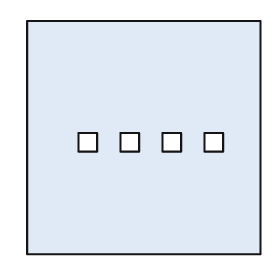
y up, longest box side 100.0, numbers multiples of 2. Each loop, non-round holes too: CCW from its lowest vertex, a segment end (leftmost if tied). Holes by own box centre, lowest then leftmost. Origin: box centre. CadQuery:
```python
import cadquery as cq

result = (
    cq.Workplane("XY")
    .moveTo(-50.0, -50.0)
    .lineTo(50.0, -50.0)
    .lineTo(50.0, 50.0)
    .lineTo(-50.0, 50.0)
    .close()
    .moveTo(-28.0, -6.0)
    .lineTo(-20.0, -6.0)
    .lineTo(-20.0, 2.0)
    .lineTo(-28.0, 2.0)
    .close()
    .moveTo(-10.0, -6.0)
    .lineTo(-2.0, -6.0)
    .lineTo(-2.0, 2.0)
    .lineTo(-10.0, 2.0)
    .close()
    .moveTo(8.0, -6.0)
    .lineTo(16.0, -6.0)
    .lineTo(16.0, 2.0)
    .lineTo(8.0, 2.0)
    .close()
    .moveTo(26.0, -6.0)
    .lineTo(34.0, -6.0)
    .lineTo(34.0, 2.0)
    .lineTo(26.0, 2.0)
    .close()
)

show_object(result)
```